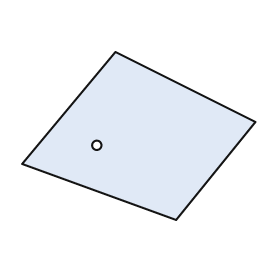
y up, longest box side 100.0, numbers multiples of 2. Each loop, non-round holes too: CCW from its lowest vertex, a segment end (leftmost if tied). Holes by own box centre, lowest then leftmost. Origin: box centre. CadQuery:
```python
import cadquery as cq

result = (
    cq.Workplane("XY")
    .moveTo(16.0, -36.0)
    .lineTo(50.0, 6.0)
    .lineTo(-10.0, 36.0)
    .lineTo(-50.0, -12.0)
    .close()
    .moveTo(-18.0, -4.0)
    .circle(2.0)
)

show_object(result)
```